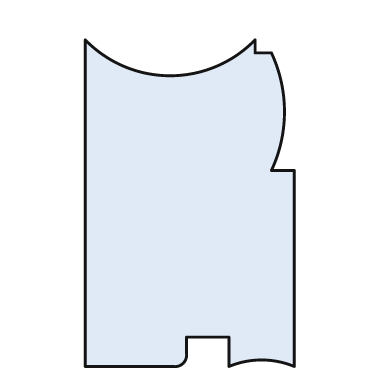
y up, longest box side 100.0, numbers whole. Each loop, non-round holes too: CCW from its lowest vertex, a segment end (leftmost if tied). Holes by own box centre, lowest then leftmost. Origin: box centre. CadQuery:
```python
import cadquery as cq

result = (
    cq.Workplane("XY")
    .moveTo(-32.0, -50.0)
    .lineTo(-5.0, -50.0)
    .threePointArc((-2.0, -49.0), (-1.0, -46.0))
    .lineTo(-1.0, -41.0)
    .lineTo(12.0, -41.0)
    .lineTo(12.0, -50.0)
    .threePointArc((22.0, -48.0), (32.0, -50.0))
    .lineTo(32.0, 10.0)
    .lineTo(25.0, 10.0)
    .threePointArc((29.0, 28.0), (25.0, 46.0))
    .lineTo(20.0, 46.0)
    .lineTo(20.0, 50.0)
    .threePointArc((-6.0, 39.0), (-32.0, 50.0))
    .close()
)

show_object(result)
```